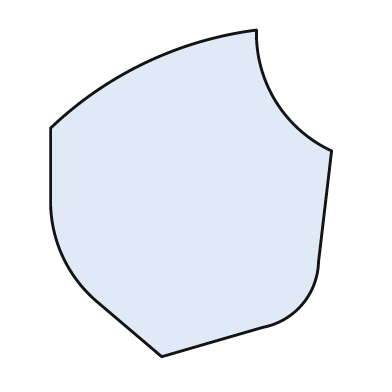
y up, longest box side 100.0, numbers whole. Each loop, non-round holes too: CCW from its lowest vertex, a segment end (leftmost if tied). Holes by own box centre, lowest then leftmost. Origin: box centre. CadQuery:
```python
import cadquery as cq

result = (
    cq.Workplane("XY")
    .moveTo(-9.0, -50.0)
    .lineTo(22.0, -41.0)
    .threePointArc((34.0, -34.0), (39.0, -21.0))
    .lineTo(43.0, 13.0)
    .threePointArc((26.0, 28.0), (20.0, 50.0))
    .threePointArc((-14.0, 40.0), (-43.0, 20.0))
    .lineTo(-43.0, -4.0)
    .threePointArc((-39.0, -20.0), (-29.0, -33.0))
    .close()
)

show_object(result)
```